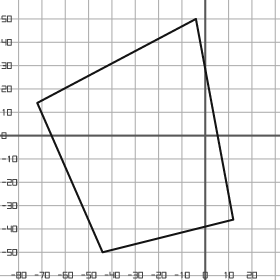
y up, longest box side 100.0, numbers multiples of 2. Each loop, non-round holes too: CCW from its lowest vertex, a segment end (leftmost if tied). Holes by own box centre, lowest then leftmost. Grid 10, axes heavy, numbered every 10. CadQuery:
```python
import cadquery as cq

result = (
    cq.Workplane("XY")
    .moveTo(-44.0, -50.0)
    .lineTo(12.0, -36.0)
    .lineTo(-4.0, 50.0)
    .lineTo(-72.0, 14.0)
    .close()
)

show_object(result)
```